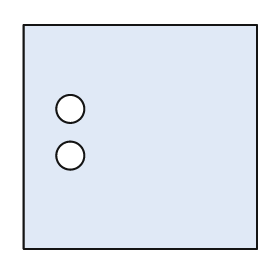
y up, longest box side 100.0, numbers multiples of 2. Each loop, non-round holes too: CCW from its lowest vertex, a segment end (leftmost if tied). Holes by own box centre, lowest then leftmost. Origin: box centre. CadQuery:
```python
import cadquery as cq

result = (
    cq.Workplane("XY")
    .moveTo(-50.0, -48.0)
    .lineTo(50.0, -48.0)
    .lineTo(50.0, 48.0)
    .lineTo(-50.0, 48.0)
    .close()
    .moveTo(-30.0, -8.0)
    .circle(6.0)
    .moveTo(-30.0, 12.0)
    .circle(6.0)
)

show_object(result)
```